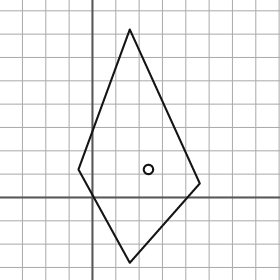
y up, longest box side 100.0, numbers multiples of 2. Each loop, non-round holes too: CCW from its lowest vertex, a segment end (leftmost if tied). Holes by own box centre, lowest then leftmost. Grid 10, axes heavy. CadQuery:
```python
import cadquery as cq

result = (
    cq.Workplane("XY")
    .moveTo(16.0, -28.0)
    .lineTo(46.0, 6.0)
    .lineTo(16.0, 72.0)
    .lineTo(-6.0, 12.0)
    .close()
    .moveTo(24.0, 12.0)
    .circle(2.0)
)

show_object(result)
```